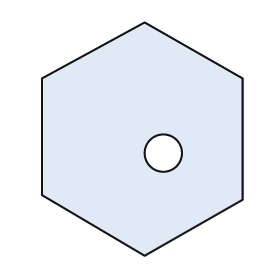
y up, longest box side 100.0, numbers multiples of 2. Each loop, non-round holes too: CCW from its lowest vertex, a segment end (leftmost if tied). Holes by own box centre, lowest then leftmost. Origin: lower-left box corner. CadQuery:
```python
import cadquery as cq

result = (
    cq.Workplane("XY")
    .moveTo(44.0, 0.0)
    .lineTo(86.0, 24.0)
    .lineTo(86.0, 76.0)
    .lineTo(44.0, 100.0)
    .lineTo(0.0, 76.0)
    .lineTo(0.0, 26.0)
    .close()
    .moveTo(52.0, 44.0)
    .circle(8.0)
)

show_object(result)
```